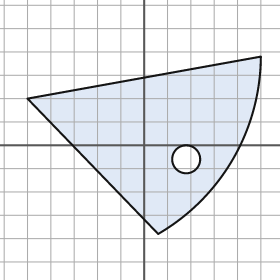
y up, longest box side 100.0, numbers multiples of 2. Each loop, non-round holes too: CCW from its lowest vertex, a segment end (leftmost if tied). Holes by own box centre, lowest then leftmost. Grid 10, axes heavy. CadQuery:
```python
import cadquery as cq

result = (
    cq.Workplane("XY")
    .moveTo(6.0, -38.0)
    .threePointArc((38.0, -6.0), (50.0, 38.0))
    .lineTo(-50.0, 20.0)
    .close()
    .moveTo(18.0, -6.0)
    .circle(6.0)
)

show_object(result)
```